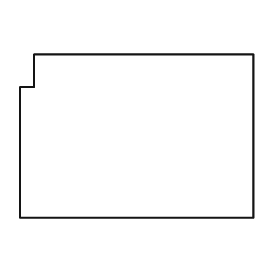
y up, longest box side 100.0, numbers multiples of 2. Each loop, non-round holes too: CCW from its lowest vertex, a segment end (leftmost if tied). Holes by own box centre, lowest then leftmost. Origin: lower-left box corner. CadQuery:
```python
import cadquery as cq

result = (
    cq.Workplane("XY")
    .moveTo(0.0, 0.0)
    .lineTo(100.0, 0.0)
    .lineTo(100.0, 70.0)
    .lineTo(6.0, 70.0)
    .lineTo(6.0, 56.0)
    .lineTo(0.0, 56.0)
    .close()
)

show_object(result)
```